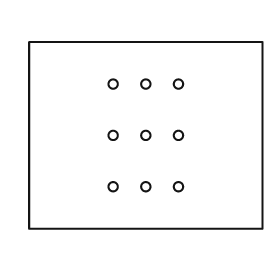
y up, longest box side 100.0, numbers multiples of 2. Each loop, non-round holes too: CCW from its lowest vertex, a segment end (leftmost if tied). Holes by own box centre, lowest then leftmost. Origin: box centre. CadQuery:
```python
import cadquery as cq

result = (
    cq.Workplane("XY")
    .moveTo(-50.0, -40.0)
    .lineTo(50.0, -40.0)
    .lineTo(50.0, 40.0)
    .lineTo(-50.0, 40.0)
    .close()
    .moveTo(-14.0, -22.0)
    .circle(2.0)
    .moveTo(0.0, -22.0)
    .circle(2.0)
    .moveTo(14.0, -22.0)
    .circle(2.0)
    .moveTo(-14.0, 0.0)
    .circle(2.0)
    .moveTo(0.0, 0.0)
    .circle(2.0)
    .moveTo(14.0, 0.0)
    .circle(2.0)
    .moveTo(-14.0, 22.0)
    .circle(2.0)
    .moveTo(0.0, 22.0)
    .circle(2.0)
    .moveTo(14.0, 22.0)
    .circle(2.0)
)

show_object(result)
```